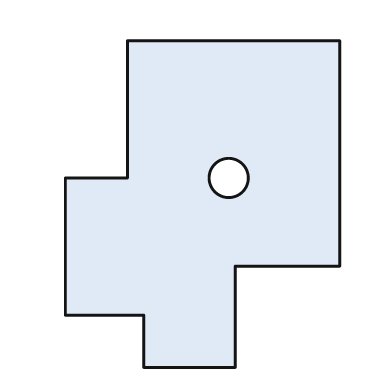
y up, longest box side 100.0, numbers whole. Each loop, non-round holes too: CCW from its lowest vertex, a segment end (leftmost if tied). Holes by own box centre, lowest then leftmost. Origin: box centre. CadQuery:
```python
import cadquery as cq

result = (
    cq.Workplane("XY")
    .moveTo(-18.0, -50.0)
    .lineTo(10.0, -50.0)
    .lineTo(10.0, -19.0)
    .lineTo(42.0, -19.0)
    .lineTo(42.0, 50.0)
    .lineTo(-23.0, 50.0)
    .lineTo(-23.0, 8.0)
    .lineTo(-42.0, 8.0)
    .lineTo(-42.0, -34.0)
    .lineTo(-18.0, -34.0)
    .close()
    .moveTo(8.0, 8.0)
    .circle(6.0)
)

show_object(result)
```